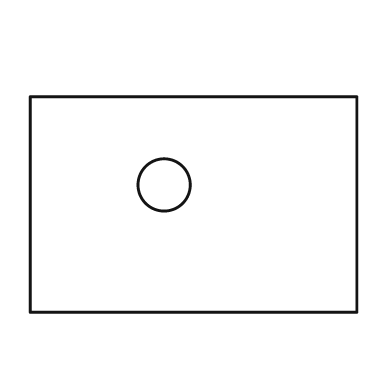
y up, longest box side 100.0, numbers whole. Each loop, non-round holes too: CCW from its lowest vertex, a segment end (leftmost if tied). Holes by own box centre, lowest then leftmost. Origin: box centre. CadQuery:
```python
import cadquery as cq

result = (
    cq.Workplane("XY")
    .moveTo(-50.0, -33.0)
    .lineTo(50.0, -33.0)
    .lineTo(50.0, 33.0)
    .lineTo(-50.0, 33.0)
    .close()
    .moveTo(-9.0, 6.0)
    .circle(8.0)
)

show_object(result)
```